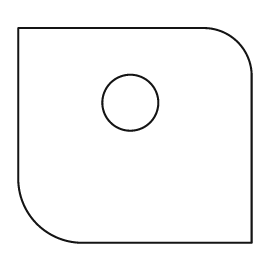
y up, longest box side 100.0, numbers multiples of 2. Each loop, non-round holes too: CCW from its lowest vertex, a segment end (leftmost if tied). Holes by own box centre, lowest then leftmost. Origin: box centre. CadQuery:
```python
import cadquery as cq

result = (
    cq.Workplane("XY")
    .moveTo(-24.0, -46.0)
    .lineTo(50.0, -46.0)
    .lineTo(50.0, 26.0)
    .threePointArc((44.0, 40.0), (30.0, 46.0))
    .lineTo(-50.0, 46.0)
    .lineTo(-50.0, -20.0)
    .threePointArc((-42.0, -38.0), (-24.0, -46.0))
    .close()
    .moveTo(-2.0, 14.0)
    .circle(12.0)
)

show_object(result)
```